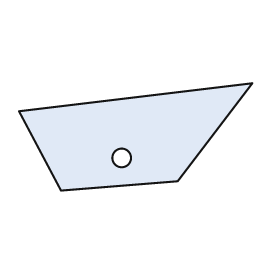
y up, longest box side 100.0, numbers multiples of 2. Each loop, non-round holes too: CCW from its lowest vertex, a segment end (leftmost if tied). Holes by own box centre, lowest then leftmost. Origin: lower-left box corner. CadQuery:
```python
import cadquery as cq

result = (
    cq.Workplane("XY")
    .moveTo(18.0, 0.0)
    .lineTo(68.0, 4.0)
    .lineTo(100.0, 46.0)
    .lineTo(0.0, 34.0)
    .close()
    .moveTo(44.0, 14.0)
    .circle(4.0)
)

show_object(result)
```